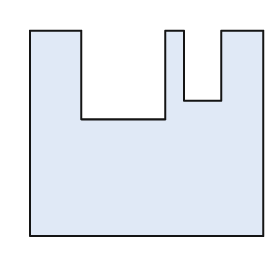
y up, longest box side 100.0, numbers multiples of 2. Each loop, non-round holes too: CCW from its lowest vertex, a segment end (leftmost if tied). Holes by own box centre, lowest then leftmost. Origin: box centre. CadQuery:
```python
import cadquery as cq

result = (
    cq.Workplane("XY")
    .moveTo(-50.0, -44.0)
    .lineTo(50.0, -44.0)
    .lineTo(50.0, 44.0)
    .lineTo(32.0, 44.0)
    .lineTo(32.0, 14.0)
    .lineTo(16.0, 14.0)
    .lineTo(16.0, 44.0)
    .lineTo(8.0, 44.0)
    .lineTo(8.0, 6.0)
    .lineTo(-28.0, 6.0)
    .lineTo(-28.0, 44.0)
    .lineTo(-50.0, 44.0)
    .close()
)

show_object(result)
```